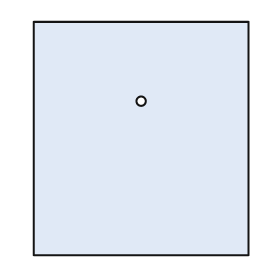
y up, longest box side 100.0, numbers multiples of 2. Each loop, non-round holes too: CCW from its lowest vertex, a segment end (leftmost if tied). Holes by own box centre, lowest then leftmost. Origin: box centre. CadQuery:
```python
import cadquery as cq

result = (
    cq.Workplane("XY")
    .moveTo(-46.0, -50.0)
    .lineTo(46.0, -50.0)
    .lineTo(46.0, 50.0)
    .lineTo(-46.0, 50.0)
    .close()
    .moveTo(0.0, 16.0)
    .circle(2.0)
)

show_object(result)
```